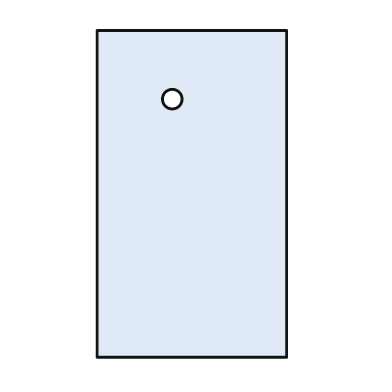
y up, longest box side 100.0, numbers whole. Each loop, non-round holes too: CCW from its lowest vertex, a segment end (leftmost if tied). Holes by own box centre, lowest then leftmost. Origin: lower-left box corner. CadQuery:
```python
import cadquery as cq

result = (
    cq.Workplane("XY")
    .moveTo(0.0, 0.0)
    .lineTo(58.0, 0.0)
    .lineTo(58.0, 100.0)
    .lineTo(0.0, 100.0)
    .close()
    .moveTo(23.0, 79.0)
    .circle(3.0)
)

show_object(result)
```